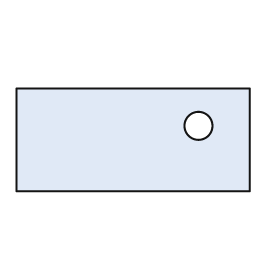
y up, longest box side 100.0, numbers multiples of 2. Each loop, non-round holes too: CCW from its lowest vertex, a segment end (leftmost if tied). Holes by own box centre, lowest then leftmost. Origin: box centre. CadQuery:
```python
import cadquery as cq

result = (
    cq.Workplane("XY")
    .moveTo(-50.0, -22.0)
    .lineTo(50.0, -22.0)
    .lineTo(50.0, 22.0)
    .lineTo(-50.0, 22.0)
    .close()
    .moveTo(28.0, 6.0)
    .circle(6.0)
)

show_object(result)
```